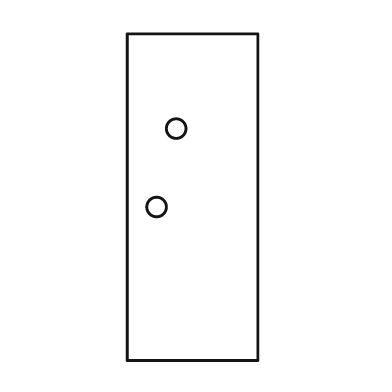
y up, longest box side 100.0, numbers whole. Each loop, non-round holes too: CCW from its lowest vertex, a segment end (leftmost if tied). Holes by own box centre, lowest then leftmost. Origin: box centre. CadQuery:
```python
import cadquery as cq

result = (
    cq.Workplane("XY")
    .moveTo(-20.0, -50.0)
    .lineTo(20.0, -50.0)
    .lineTo(20.0, 50.0)
    .lineTo(-20.0, 50.0)
    .close()
    .moveTo(-11.0, -3.0)
    .circle(3.0)
    .moveTo(-5.0, 21.0)
    .circle(3.0)
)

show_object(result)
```